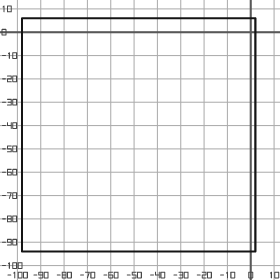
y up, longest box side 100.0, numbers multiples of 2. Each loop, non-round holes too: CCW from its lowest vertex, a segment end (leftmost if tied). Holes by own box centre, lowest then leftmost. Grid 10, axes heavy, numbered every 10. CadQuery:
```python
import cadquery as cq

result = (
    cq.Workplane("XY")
    .moveTo(-98.0, -94.0)
    .lineTo(2.0, -94.0)
    .lineTo(2.0, 6.0)
    .lineTo(-98.0, 6.0)
    .close()
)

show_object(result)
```